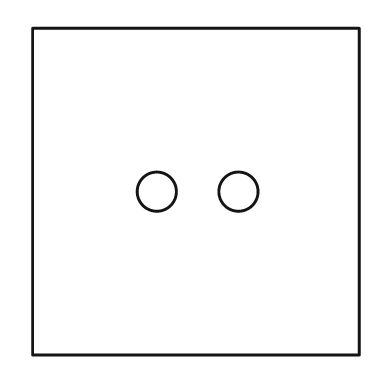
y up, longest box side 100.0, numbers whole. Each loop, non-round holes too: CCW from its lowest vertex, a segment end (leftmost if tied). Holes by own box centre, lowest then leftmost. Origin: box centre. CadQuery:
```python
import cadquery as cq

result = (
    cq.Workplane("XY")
    .moveTo(-50.0, -50.0)
    .lineTo(50.0, -50.0)
    .lineTo(50.0, 50.0)
    .lineTo(-50.0, 50.0)
    .close()
    .moveTo(-12.0, 0.0)
    .circle(6.0)
    .moveTo(13.0, 0.0)
    .circle(6.0)
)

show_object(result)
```